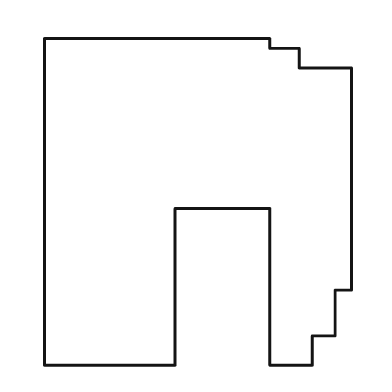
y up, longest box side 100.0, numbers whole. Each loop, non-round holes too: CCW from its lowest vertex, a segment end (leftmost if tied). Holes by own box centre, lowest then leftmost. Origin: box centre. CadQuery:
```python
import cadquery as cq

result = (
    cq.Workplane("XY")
    .moveTo(-47.0, -50.0)
    .lineTo(-7.0, -50.0)
    .lineTo(-7.0, -2.0)
    .lineTo(22.0, -2.0)
    .lineTo(22.0, -50.0)
    .lineTo(35.0, -50.0)
    .lineTo(35.0, -41.0)
    .lineTo(42.0, -41.0)
    .lineTo(42.0, -27.0)
    .lineTo(47.0, -27.0)
    .lineTo(47.0, 41.0)
    .lineTo(31.0, 41.0)
    .lineTo(31.0, 47.0)
    .lineTo(22.0, 47.0)
    .lineTo(22.0, 50.0)
    .lineTo(-47.0, 50.0)
    .close()
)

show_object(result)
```